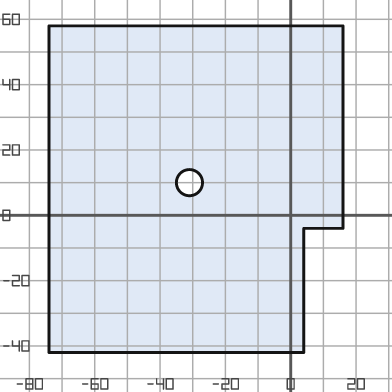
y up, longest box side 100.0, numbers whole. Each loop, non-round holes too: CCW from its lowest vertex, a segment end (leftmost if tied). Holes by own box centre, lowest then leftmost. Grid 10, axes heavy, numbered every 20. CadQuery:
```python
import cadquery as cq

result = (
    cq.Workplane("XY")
    .moveTo(-74.0, -42.0)
    .lineTo(4.0, -42.0)
    .lineTo(4.0, -4.0)
    .lineTo(16.0, -4.0)
    .lineTo(16.0, 58.0)
    .lineTo(-74.0, 58.0)
    .close()
    .moveTo(-31.0, 10.0)
    .circle(4.0)
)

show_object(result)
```